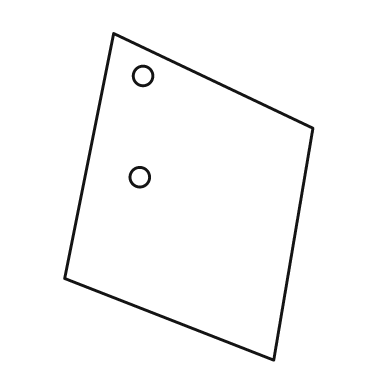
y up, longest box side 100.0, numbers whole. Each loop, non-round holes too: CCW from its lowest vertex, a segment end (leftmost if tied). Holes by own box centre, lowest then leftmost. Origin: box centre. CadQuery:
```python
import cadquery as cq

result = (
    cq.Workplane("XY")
    .moveTo(26.0, -50.0)
    .lineTo(38.0, 21.0)
    .lineTo(-23.0, 50.0)
    .lineTo(-38.0, -25.0)
    .close()
    .moveTo(-15.0, 6.0)
    .circle(3.0)
    .moveTo(-14.0, 37.0)
    .circle(3.0)
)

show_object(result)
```